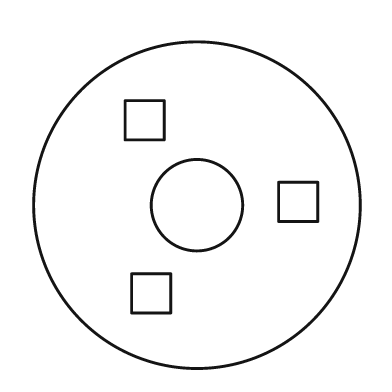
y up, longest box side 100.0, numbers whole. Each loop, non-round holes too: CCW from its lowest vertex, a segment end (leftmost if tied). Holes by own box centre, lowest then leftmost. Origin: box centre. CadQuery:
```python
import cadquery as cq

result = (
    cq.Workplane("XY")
    .moveTo(0.0, 0.0)
    .circle(50.0)
    .moveTo(-20.0, -33.0)
    .lineTo(-8.0, -33.0)
    .lineTo(-8.0, -21.0)
    .lineTo(-20.0, -21.0)
    .close()
    .moveTo(0.0, 0.0)
    .circle(14.0)
    .moveTo(25.0, -5.0)
    .lineTo(37.0, -5.0)
    .lineTo(37.0, 7.0)
    .lineTo(25.0, 7.0)
    .close()
    .moveTo(-22.0, 20.0)
    .lineTo(-10.0, 20.0)
    .lineTo(-10.0, 32.0)
    .lineTo(-22.0, 32.0)
    .close()
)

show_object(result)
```